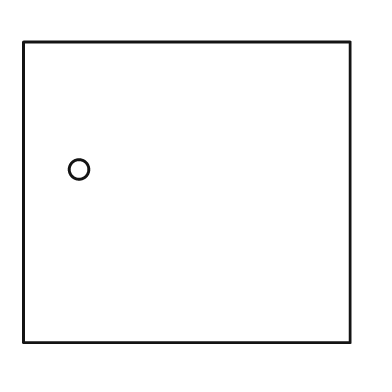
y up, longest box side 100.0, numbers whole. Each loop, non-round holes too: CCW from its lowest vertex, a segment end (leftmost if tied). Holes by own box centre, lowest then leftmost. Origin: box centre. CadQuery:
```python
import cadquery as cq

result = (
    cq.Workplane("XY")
    .moveTo(-50.0, -46.0)
    .lineTo(50.0, -46.0)
    .lineTo(50.0, 46.0)
    .lineTo(-50.0, 46.0)
    .close()
    .moveTo(-33.0, 7.0)
    .circle(3.0)
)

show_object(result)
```